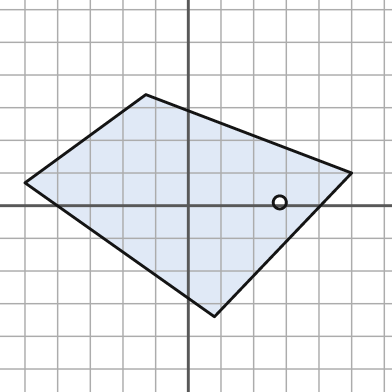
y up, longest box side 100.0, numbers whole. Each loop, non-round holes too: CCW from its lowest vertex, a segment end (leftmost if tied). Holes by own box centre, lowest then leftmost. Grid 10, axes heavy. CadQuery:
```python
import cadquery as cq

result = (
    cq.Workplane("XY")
    .moveTo(8.0, -34.0)
    .lineTo(50.0, 10.0)
    .lineTo(-13.0, 34.0)
    .lineTo(-50.0, 7.0)
    .close()
    .moveTo(28.0, 1.0)
    .circle(2.0)
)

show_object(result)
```